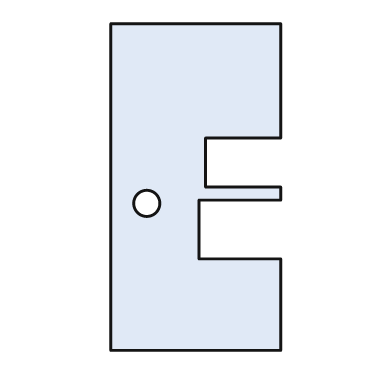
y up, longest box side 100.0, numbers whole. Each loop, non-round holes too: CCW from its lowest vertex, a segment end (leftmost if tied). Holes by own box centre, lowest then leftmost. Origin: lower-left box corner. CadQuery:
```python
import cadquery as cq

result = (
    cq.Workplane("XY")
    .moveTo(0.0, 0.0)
    .lineTo(52.0, 0.0)
    .lineTo(52.0, 28.0)
    .lineTo(27.0, 28.0)
    .lineTo(27.0, 46.0)
    .lineTo(52.0, 46.0)
    .lineTo(52.0, 50.0)
    .lineTo(29.0, 50.0)
    .lineTo(29.0, 65.0)
    .lineTo(52.0, 65.0)
    .lineTo(52.0, 100.0)
    .lineTo(0.0, 100.0)
    .close()
    .moveTo(11.0, 45.0)
    .circle(4.0)
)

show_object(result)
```